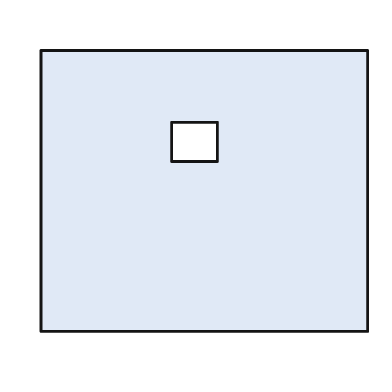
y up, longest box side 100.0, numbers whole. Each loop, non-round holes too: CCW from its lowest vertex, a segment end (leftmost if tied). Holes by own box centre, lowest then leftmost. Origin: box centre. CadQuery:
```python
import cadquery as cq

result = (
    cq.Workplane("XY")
    .moveTo(-50.0, -43.0)
    .lineTo(50.0, -43.0)
    .lineTo(50.0, 43.0)
    .lineTo(-50.0, 43.0)
    .close()
    .moveTo(-10.0, 9.0)
    .lineTo(4.0, 9.0)
    .lineTo(4.0, 21.0)
    .lineTo(-10.0, 21.0)
    .close()
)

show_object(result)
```